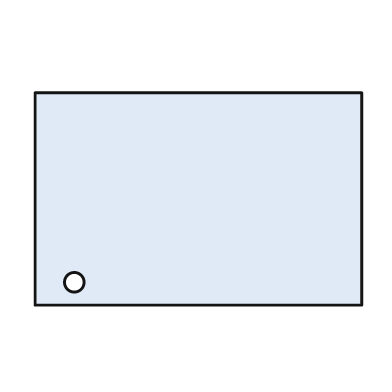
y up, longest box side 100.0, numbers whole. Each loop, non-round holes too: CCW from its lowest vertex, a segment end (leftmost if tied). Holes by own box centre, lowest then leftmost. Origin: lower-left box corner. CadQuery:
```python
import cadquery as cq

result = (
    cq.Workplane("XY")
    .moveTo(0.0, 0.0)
    .lineTo(100.0, 0.0)
    .lineTo(100.0, 65.0)
    .lineTo(0.0, 65.0)
    .close()
    .moveTo(12.0, 7.0)
    .circle(3.0)
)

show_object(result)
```